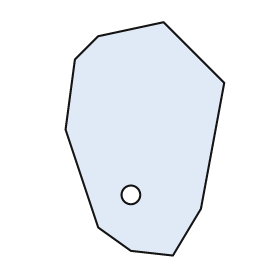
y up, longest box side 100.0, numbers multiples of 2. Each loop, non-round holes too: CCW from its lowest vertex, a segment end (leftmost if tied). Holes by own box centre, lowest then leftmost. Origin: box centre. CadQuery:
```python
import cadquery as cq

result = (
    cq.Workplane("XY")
    .moveTo(12.0, -50.0)
    .lineTo(24.0, -30.0)
    .lineTo(34.0, 24.0)
    .lineTo(8.0, 50.0)
    .lineTo(-20.0, 44.0)
    .lineTo(-30.0, 34.0)
    .lineTo(-34.0, 4.0)
    .lineTo(-20.0, -38.0)
    .lineTo(-6.0, -48.0)
    .close()
    .moveTo(-6.0, -24.0)
    .circle(4.0)
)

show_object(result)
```